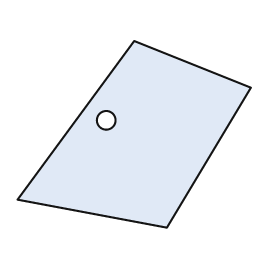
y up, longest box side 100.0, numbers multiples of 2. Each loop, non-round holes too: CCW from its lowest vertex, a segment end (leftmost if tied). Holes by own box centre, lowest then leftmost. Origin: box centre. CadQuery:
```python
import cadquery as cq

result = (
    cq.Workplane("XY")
    .moveTo(14.0, -40.0)
    .lineTo(50.0, 20.0)
    .lineTo(0.0, 40.0)
    .lineTo(-50.0, -28.0)
    .close()
    .moveTo(-12.0, 6.0)
    .circle(4.0)
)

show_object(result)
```